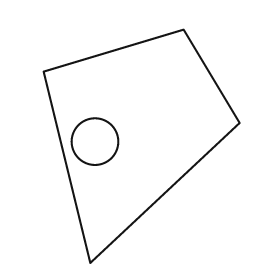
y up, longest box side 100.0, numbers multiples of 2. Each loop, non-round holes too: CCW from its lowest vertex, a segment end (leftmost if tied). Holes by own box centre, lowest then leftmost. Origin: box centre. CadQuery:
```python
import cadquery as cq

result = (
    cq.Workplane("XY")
    .moveTo(-22.0, -50.0)
    .lineTo(42.0, 10.0)
    .lineTo(18.0, 50.0)
    .lineTo(-42.0, 32.0)
    .close()
    .moveTo(-20.0, 2.0)
    .circle(10.0)
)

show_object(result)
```